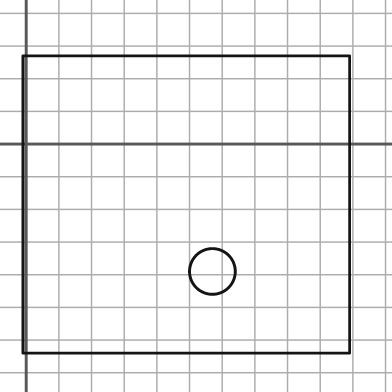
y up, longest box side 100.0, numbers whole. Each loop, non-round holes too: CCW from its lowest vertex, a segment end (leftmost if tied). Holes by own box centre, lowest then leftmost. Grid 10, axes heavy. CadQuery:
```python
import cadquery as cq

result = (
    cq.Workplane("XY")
    .moveTo(-1.0, -64.0)
    .lineTo(99.0, -64.0)
    .lineTo(99.0, 27.0)
    .lineTo(-1.0, 27.0)
    .close()
    .moveTo(57.0, -39.0)
    .circle(7.0)
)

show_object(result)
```